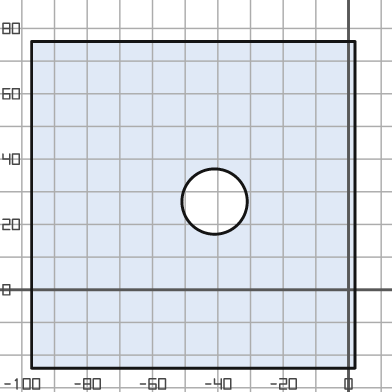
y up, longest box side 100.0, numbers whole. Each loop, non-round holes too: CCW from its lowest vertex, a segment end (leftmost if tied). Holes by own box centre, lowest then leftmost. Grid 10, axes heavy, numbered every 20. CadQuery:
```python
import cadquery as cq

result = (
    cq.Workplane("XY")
    .moveTo(-97.0, -24.0)
    .lineTo(2.0, -24.0)
    .lineTo(2.0, 76.0)
    .lineTo(-97.0, 76.0)
    .close()
    .moveTo(-41.0, 27.0)
    .circle(10.0)
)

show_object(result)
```